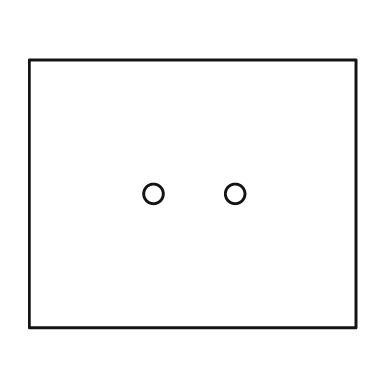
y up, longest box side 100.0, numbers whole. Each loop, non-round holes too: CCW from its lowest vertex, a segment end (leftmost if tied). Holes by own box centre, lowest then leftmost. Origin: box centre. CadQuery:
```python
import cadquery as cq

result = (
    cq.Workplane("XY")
    .moveTo(-50.0, -41.0)
    .lineTo(50.0, -41.0)
    .lineTo(50.0, 41.0)
    .lineTo(-50.0, 41.0)
    .close()
    .moveTo(-12.0, 0.0)
    .circle(3.0)
    .moveTo(13.0, 0.0)
    .circle(3.0)
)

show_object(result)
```